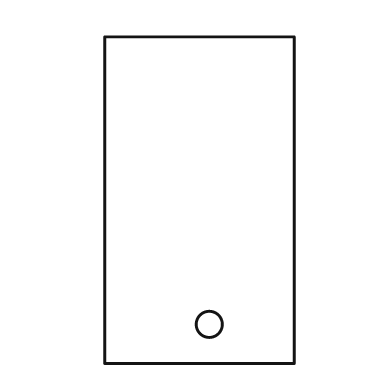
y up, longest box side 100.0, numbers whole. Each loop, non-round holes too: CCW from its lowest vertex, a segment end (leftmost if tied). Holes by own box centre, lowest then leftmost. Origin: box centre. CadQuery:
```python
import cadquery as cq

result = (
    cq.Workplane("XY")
    .moveTo(-29.0, -50.0)
    .lineTo(29.0, -50.0)
    .lineTo(29.0, 50.0)
    .lineTo(-29.0, 50.0)
    .close()
    .moveTo(3.0, -38.0)
    .circle(4.0)
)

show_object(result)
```